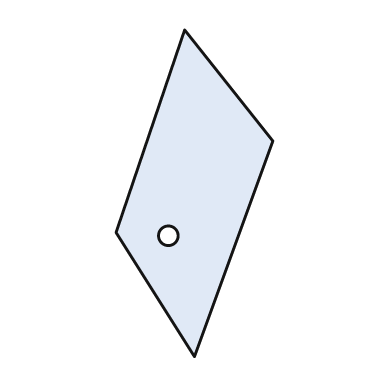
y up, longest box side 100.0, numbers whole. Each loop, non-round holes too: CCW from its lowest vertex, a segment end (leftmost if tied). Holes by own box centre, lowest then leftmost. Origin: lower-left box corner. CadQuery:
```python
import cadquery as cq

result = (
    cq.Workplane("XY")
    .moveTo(24.0, 0.0)
    .lineTo(48.0, 66.0)
    .lineTo(21.0, 100.0)
    .lineTo(0.0, 38.0)
    .close()
    .moveTo(16.0, 37.0)
    .circle(3.0)
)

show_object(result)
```